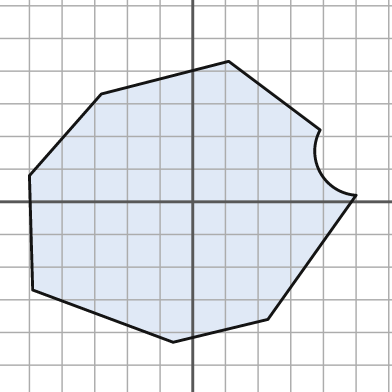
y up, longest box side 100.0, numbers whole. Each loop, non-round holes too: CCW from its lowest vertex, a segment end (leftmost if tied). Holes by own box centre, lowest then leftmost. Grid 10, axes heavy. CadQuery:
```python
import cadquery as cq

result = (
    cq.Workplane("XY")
    .moveTo(-6.0, -43.0)
    .lineTo(23.0, -36.0)
    .lineTo(50.0, 2.0)
    .threePointArc((39.0, 9.0), (39.0, 22.0))
    .lineTo(11.0, 43.0)
    .lineTo(-28.0, 33.0)
    .lineTo(-50.0, 8.0)
    .lineTo(-49.0, -27.0)
    .close()
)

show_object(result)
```